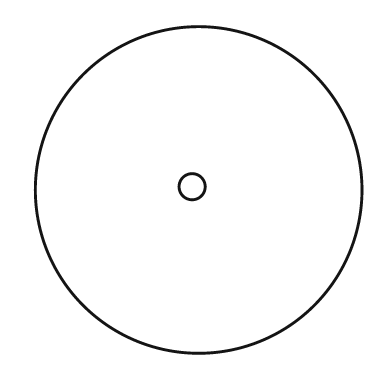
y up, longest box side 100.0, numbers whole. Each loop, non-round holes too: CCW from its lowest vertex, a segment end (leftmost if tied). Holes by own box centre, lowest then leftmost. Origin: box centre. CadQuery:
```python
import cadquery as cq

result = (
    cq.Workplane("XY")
    .moveTo(0.0, 0.0)
    .circle(50.0)
    .moveTo(-2.0, 1.0)
    .circle(4.0)
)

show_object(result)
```